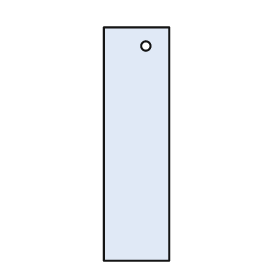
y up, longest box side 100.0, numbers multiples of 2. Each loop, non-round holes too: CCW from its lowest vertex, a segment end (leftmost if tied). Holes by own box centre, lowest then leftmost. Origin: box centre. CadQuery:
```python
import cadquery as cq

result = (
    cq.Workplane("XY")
    .moveTo(-14.0, -50.0)
    .lineTo(14.0, -50.0)
    .lineTo(14.0, 50.0)
    .lineTo(-14.0, 50.0)
    .close()
    .moveTo(4.0, 42.0)
    .circle(2.0)
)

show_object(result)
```